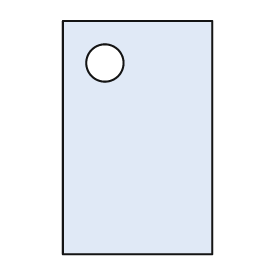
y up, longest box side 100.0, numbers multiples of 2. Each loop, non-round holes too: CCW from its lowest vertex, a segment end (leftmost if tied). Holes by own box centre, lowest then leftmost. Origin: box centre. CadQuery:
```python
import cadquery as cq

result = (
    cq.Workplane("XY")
    .moveTo(-32.0, -50.0)
    .lineTo(32.0, -50.0)
    .lineTo(32.0, 50.0)
    .lineTo(-32.0, 50.0)
    .close()
    .moveTo(-14.0, 32.0)
    .circle(8.0)
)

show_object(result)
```